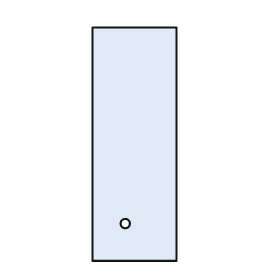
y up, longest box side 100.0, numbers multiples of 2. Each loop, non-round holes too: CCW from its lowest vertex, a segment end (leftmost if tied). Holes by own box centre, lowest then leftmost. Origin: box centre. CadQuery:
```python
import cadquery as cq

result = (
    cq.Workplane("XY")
    .moveTo(-18.0, -50.0)
    .lineTo(18.0, -50.0)
    .lineTo(18.0, 50.0)
    .lineTo(-18.0, 50.0)
    .close()
    .moveTo(-4.0, -34.0)
    .circle(2.0)
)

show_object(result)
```